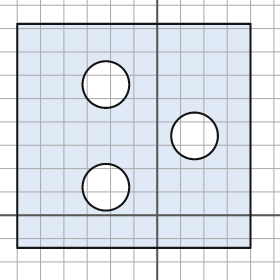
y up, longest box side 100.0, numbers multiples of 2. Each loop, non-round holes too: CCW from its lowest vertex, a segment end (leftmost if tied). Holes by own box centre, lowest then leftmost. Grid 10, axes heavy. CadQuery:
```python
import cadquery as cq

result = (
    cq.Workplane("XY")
    .moveTo(-60.0, -14.0)
    .lineTo(40.0, -14.0)
    .lineTo(40.0, 82.0)
    .lineTo(-60.0, 82.0)
    .close()
    .moveTo(-22.0, 12.0)
    .circle(10.0)
    .moveTo(16.0, 34.0)
    .circle(10.0)
    .moveTo(-22.0, 56.0)
    .circle(10.0)
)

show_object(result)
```